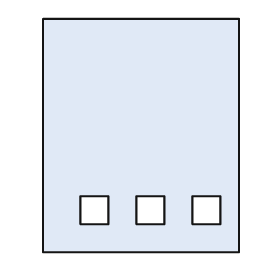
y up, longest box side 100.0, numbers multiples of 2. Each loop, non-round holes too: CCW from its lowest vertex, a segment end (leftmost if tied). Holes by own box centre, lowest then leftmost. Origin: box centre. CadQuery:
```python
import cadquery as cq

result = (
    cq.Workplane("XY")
    .moveTo(-42.0, -50.0)
    .lineTo(42.0, -50.0)
    .lineTo(42.0, 50.0)
    .lineTo(-42.0, 50.0)
    .close()
    .moveTo(-26.0, -38.0)
    .lineTo(-14.0, -38.0)
    .lineTo(-14.0, -26.0)
    .lineTo(-26.0, -26.0)
    .close()
    .moveTo(-2.0, -38.0)
    .lineTo(10.0, -38.0)
    .lineTo(10.0, -26.0)
    .lineTo(-2.0, -26.0)
    .close()
    .moveTo(22.0, -38.0)
    .lineTo(34.0, -38.0)
    .lineTo(34.0, -26.0)
    .lineTo(22.0, -26.0)
    .close()
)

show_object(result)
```